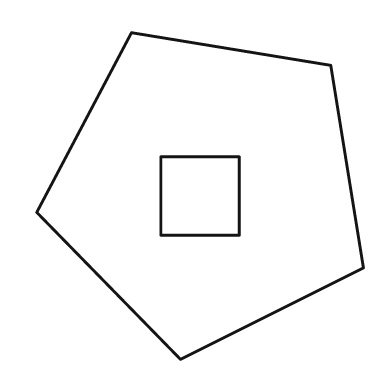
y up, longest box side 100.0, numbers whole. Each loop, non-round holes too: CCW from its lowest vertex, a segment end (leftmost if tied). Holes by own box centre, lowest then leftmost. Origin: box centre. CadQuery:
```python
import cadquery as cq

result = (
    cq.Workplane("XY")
    .moveTo(-6.0, -50.0)
    .lineTo(50.0, -22.0)
    .lineTo(40.0, 40.0)
    .lineTo(-21.0, 50.0)
    .lineTo(-50.0, -5.0)
    .close()
    .moveTo(-12.0, -12.0)
    .lineTo(12.0, -12.0)
    .lineTo(12.0, 12.0)
    .lineTo(-12.0, 12.0)
    .close()
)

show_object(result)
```